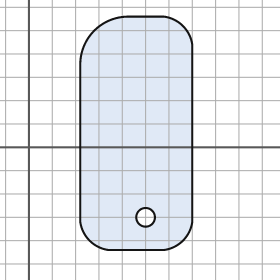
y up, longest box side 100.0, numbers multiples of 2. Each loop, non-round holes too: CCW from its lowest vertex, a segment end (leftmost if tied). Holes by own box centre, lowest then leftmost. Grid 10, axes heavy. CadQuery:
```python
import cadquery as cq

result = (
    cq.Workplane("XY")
    .moveTo(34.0, -44.0)
    .lineTo(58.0, -44.0)
    .threePointArc((66.0, -40.0), (70.0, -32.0))
    .lineTo(70.0, 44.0)
    .threePointArc((66.0, 52.0), (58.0, 56.0))
    .lineTo(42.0, 56.0)
    .threePointArc((28.0, 50.0), (22.0, 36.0))
    .lineTo(22.0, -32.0)
    .threePointArc((26.0, -40.0), (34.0, -44.0))
    .close()
    .moveTo(50.0, -30.0)
    .circle(4.0)
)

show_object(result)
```